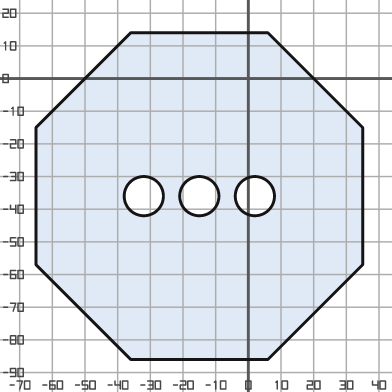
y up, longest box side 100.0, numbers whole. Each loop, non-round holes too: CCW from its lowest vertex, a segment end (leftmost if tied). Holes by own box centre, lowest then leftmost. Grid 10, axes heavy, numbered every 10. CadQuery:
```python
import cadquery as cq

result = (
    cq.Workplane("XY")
    .moveTo(-36.0, -86.0)
    .lineTo(6.0, -86.0)
    .lineTo(35.0, -57.0)
    .lineTo(35.0, -15.0)
    .lineTo(6.0, 14.0)
    .lineTo(-36.0, 14.0)
    .lineTo(-65.0, -15.0)
    .lineTo(-65.0, -57.0)
    .close()
    .moveTo(-32.0, -36.0)
    .circle(6.0)
    .moveTo(-15.0, -36.0)
    .circle(6.0)
    .moveTo(2.0, -36.0)
    .circle(6.0)
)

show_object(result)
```